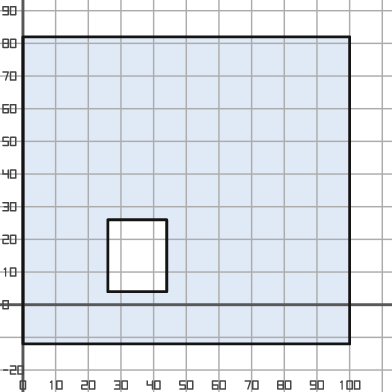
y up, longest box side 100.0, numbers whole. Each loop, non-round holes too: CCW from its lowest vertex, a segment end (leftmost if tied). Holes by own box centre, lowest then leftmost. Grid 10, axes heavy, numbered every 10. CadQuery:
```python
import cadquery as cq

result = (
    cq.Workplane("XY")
    .moveTo(0.0, -12.0)
    .lineTo(100.0, -12.0)
    .lineTo(100.0, 82.0)
    .lineTo(0.0, 82.0)
    .close()
    .moveTo(26.0, 4.0)
    .lineTo(44.0, 4.0)
    .lineTo(44.0, 26.0)
    .lineTo(26.0, 26.0)
    .close()
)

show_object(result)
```